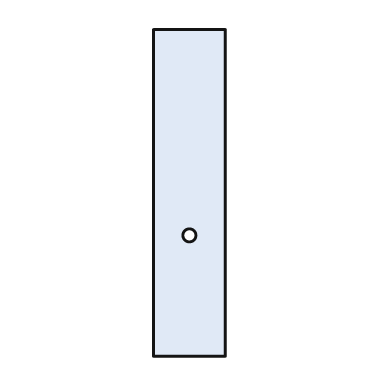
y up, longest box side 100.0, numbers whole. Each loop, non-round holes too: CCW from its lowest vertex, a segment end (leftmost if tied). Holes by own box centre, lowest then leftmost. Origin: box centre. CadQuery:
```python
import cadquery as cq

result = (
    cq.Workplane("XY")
    .moveTo(-11.0, -50.0)
    .lineTo(11.0, -50.0)
    .lineTo(11.0, 50.0)
    .lineTo(-11.0, 50.0)
    .close()
    .moveTo(0.0, -13.0)
    .circle(2.0)
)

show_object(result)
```